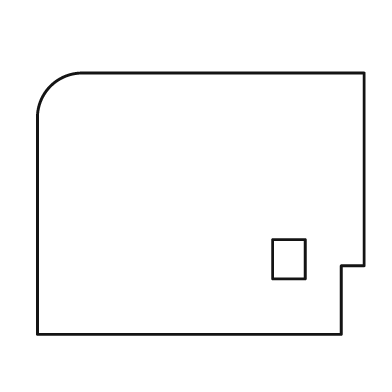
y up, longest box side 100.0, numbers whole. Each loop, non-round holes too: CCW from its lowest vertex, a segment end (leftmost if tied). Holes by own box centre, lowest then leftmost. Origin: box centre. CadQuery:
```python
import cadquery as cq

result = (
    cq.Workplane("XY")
    .moveTo(-50.0, -40.0)
    .lineTo(43.0, -40.0)
    .lineTo(43.0, -19.0)
    .lineTo(50.0, -19.0)
    .lineTo(50.0, 40.0)
    .lineTo(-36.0, 40.0)
    .threePointArc((-46.0, 36.0), (-50.0, 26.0))
    .close()
    .moveTo(22.0, -23.0)
    .lineTo(32.0, -23.0)
    .lineTo(32.0, -11.0)
    .lineTo(22.0, -11.0)
    .close()
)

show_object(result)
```